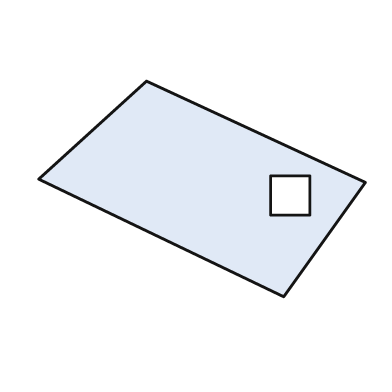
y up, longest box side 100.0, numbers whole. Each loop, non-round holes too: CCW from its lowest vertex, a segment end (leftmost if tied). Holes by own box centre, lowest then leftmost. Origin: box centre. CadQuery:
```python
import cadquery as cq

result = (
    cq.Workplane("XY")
    .moveTo(25.0, -33.0)
    .lineTo(50.0, 2.0)
    .lineTo(-17.0, 33.0)
    .lineTo(-50.0, 3.0)
    .close()
    .moveTo(21.0, -8.0)
    .lineTo(33.0, -8.0)
    .lineTo(33.0, 4.0)
    .lineTo(21.0, 4.0)
    .close()
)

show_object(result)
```